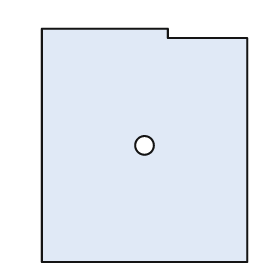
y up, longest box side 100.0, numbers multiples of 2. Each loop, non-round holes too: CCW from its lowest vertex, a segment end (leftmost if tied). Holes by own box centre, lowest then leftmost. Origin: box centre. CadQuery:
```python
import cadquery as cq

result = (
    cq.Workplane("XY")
    .moveTo(-44.0, -50.0)
    .lineTo(44.0, -50.0)
    .lineTo(44.0, 46.0)
    .lineTo(10.0, 46.0)
    .lineTo(10.0, 50.0)
    .lineTo(-44.0, 50.0)
    .close()
    .moveTo(0.0, 0.0)
    .circle(4.0)
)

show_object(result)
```